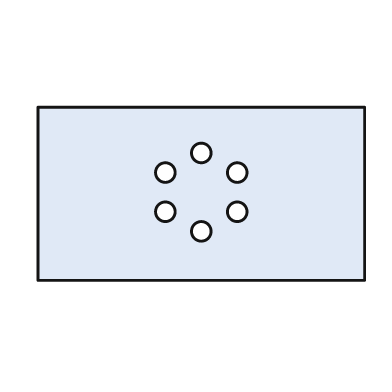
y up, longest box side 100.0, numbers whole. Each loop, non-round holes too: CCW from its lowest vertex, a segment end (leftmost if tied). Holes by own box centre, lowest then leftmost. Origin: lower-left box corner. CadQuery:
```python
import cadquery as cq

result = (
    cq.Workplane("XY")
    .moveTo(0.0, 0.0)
    .lineTo(100.0, 0.0)
    .lineTo(100.0, 53.0)
    .lineTo(0.0, 53.0)
    .close()
    .moveTo(50.0, 15.0)
    .circle(3.0)
    .moveTo(39.0, 21.0)
    .circle(3.0)
    .moveTo(61.0, 21.0)
    .circle(3.0)
    .moveTo(39.0, 33.0)
    .circle(3.0)
    .moveTo(61.0, 33.0)
    .circle(3.0)
    .moveTo(50.0, 39.0)
    .circle(3.0)
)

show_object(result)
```